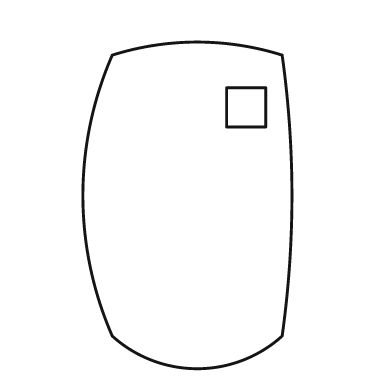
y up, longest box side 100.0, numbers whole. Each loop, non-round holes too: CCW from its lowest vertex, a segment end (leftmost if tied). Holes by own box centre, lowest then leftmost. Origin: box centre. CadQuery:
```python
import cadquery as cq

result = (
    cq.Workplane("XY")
    .moveTo(-23.0, -40.0)
    .threePointArc((3.0, -50.0), (29.0, -40.0))
    .threePointArc((32.0, 3.0), (29.0, 46.0))
    .threePointArc((3.0, 50.0), (-23.0, 46.0))
    .threePointArc((-32.0, 3.0), (-23.0, -40.0))
    .close()
    .moveTo(12.0, 24.0)
    .lineTo(24.0, 24.0)
    .lineTo(24.0, 36.0)
    .lineTo(12.0, 36.0)
    .close()
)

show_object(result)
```